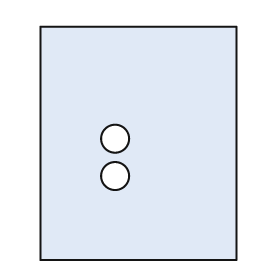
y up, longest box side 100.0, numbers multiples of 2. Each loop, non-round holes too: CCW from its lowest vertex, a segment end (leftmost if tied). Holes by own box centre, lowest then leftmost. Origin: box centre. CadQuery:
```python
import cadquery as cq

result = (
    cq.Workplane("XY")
    .moveTo(-42.0, -50.0)
    .lineTo(42.0, -50.0)
    .lineTo(42.0, 50.0)
    .lineTo(-42.0, 50.0)
    .close()
    .moveTo(-10.0, -14.0)
    .circle(6.0)
    .moveTo(-10.0, 2.0)
    .circle(6.0)
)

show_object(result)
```